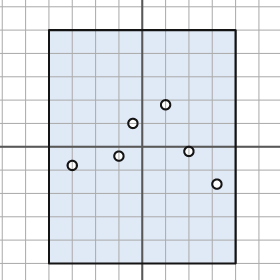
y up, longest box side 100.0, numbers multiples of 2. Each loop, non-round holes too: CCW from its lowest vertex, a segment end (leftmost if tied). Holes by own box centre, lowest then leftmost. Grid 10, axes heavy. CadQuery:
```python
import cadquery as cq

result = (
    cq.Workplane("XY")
    .moveTo(-40.0, -50.0)
    .lineTo(40.0, -50.0)
    .lineTo(40.0, 50.0)
    .lineTo(-40.0, 50.0)
    .close()
    .moveTo(32.0, -16.0)
    .circle(2.0)
    .moveTo(-30.0, -8.0)
    .circle(2.0)
    .moveTo(-10.0, -4.0)
    .circle(2.0)
    .moveTo(20.0, -2.0)
    .circle(2.0)
    .moveTo(-4.0, 10.0)
    .circle(2.0)
    .moveTo(10.0, 18.0)
    .circle(2.0)
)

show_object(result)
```